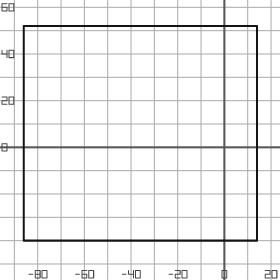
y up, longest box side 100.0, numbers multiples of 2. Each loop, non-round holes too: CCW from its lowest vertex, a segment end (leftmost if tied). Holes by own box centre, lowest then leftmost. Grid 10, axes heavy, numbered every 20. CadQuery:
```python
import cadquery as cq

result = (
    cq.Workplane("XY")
    .moveTo(-86.0, -40.0)
    .lineTo(14.0, -40.0)
    .lineTo(14.0, 52.0)
    .lineTo(-86.0, 52.0)
    .close()
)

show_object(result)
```